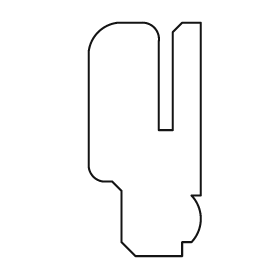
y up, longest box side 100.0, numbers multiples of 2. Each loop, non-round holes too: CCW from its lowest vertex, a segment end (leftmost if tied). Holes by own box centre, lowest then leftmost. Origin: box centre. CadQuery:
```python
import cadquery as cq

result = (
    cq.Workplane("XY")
    .moveTo(-4.0, -50.0)
    .lineTo(16.0, -50.0)
    .lineTo(16.0, -44.0)
    .lineTo(20.0, -44.0)
    .threePointArc((24.0, -34.0), (20.0, -24.0))
    .lineTo(24.0, -24.0)
    .lineTo(24.0, 50.0)
    .lineTo(16.0, 50.0)
    .lineTo(12.0, 46.0)
    .lineTo(12.0, 4.0)
    .lineTo(6.0, 4.0)
    .lineTo(6.0, 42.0)
    .threePointArc((4.0, 48.0), (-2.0, 50.0))
    .lineTo(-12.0, 50.0)
    .threePointArc((-20.0, 46.0), (-24.0, 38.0))
    .lineTo(-24.0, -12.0)
    .threePointArc((-22.0, -16.0), (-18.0, -18.0))
    .lineTo(-14.0, -18.0)
    .lineTo(-10.0, -22.0)
    .lineTo(-10.0, -44.0)
    .close()
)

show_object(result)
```